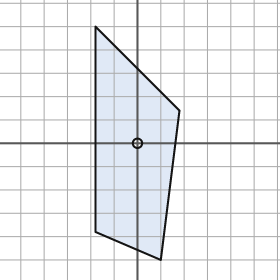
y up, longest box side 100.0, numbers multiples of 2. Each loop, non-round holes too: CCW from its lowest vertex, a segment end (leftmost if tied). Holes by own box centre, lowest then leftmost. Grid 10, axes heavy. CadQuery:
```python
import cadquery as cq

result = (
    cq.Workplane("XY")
    .moveTo(10.0, -50.0)
    .lineTo(18.0, 14.0)
    .lineTo(-18.0, 50.0)
    .lineTo(-18.0, -38.0)
    .close()
    .moveTo(0.0, 0.0)
    .circle(2.0)
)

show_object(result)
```